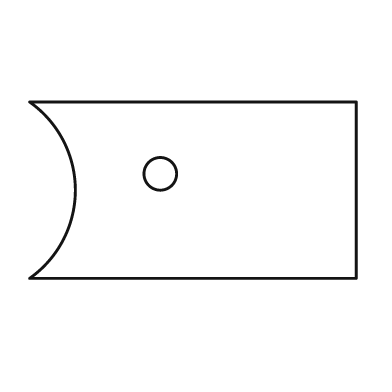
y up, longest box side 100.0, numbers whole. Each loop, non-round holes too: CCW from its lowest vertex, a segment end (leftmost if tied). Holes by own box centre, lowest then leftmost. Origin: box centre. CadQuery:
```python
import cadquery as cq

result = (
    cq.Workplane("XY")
    .moveTo(-50.0, -27.0)
    .lineTo(50.0, -27.0)
    .lineTo(50.0, 27.0)
    .lineTo(-50.0, 27.0)
    .threePointArc((-36.0, 0.0), (-50.0, -27.0))
    .close()
    .moveTo(-10.0, 5.0)
    .circle(5.0)
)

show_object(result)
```